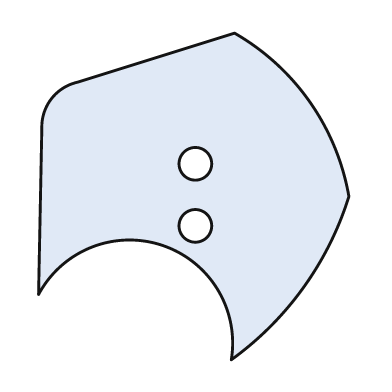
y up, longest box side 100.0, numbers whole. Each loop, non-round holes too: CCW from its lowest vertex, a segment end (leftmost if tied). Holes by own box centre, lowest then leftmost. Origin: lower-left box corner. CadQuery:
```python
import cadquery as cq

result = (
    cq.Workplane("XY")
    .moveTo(59.0, 0.0)
    .threePointArc((81.0, 22.0), (95.0, 50.0))
    .threePointArc((83.0, 79.0), (60.0, 100.0))
    .lineTo(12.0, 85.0)
    .threePointArc((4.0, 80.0), (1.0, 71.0))
    .lineTo(0.0, 20.0)
    .threePointArc((38.0, 35.0), (59.0, 0.0))
    .close()
    .moveTo(48.0, 41.0)
    .circle(5.0)
    .moveTo(48.0, 60.0)
    .circle(5.0)
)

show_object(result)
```